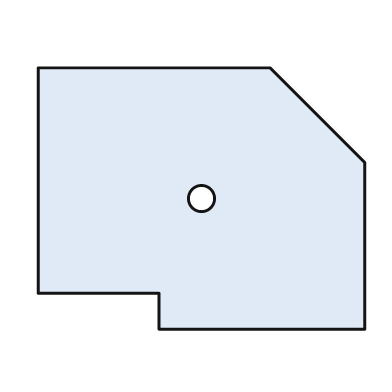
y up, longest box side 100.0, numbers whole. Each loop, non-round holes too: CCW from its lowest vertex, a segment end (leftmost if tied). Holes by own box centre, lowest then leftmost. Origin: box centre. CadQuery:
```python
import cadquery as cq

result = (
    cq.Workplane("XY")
    .moveTo(-13.0, -40.0)
    .lineTo(50.0, -40.0)
    .lineTo(50.0, 11.0)
    .lineTo(21.0, 40.0)
    .lineTo(-50.0, 40.0)
    .lineTo(-50.0, -29.0)
    .lineTo(-13.0, -29.0)
    .close()
    .moveTo(0.0, 0.0)
    .circle(4.0)
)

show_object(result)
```